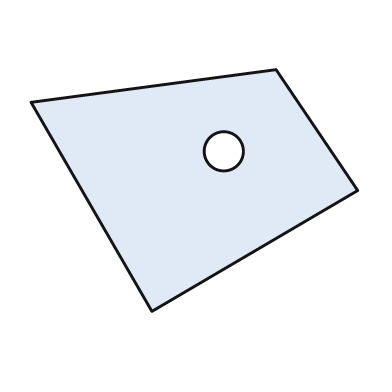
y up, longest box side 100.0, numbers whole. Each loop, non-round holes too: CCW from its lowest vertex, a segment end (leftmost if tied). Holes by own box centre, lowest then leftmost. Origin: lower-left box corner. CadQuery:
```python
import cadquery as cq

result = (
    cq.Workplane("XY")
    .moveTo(37.0, 0.0)
    .lineTo(100.0, 37.0)
    .lineTo(75.0, 74.0)
    .lineTo(0.0, 64.0)
    .close()
    .moveTo(59.0, 49.0)
    .circle(6.0)
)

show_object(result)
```